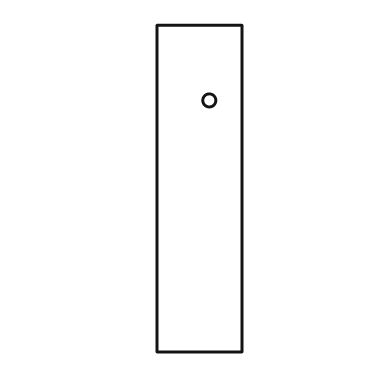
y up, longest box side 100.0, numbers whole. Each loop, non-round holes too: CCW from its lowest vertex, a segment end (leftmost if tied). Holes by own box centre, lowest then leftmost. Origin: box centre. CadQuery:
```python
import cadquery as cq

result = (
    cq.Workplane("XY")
    .moveTo(-13.0, -50.0)
    .lineTo(13.0, -50.0)
    .lineTo(13.0, 50.0)
    .lineTo(-13.0, 50.0)
    .close()
    .moveTo(3.0, 27.0)
    .circle(2.0)
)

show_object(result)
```